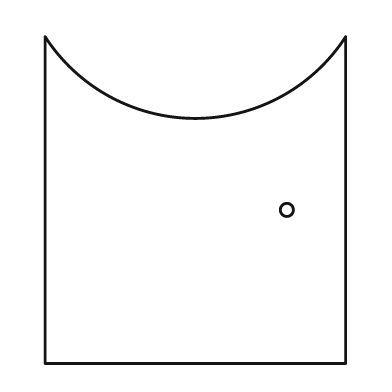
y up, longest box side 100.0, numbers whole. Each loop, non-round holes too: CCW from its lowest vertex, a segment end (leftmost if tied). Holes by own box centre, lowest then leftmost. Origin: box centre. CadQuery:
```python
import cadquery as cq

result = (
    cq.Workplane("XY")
    .moveTo(-46.0, -50.0)
    .lineTo(46.0, -50.0)
    .lineTo(46.0, 50.0)
    .threePointArc((0.0, 25.0), (-46.0, 50.0))
    .close()
    .moveTo(28.0, -3.0)
    .circle(2.0)
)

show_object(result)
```